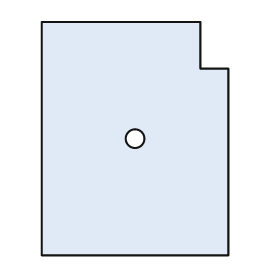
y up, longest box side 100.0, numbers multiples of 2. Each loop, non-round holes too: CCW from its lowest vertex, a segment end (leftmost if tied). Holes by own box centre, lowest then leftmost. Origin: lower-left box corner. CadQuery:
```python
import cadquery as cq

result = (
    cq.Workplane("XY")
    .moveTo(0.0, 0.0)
    .lineTo(80.0, 0.0)
    .lineTo(80.0, 80.0)
    .lineTo(68.0, 80.0)
    .lineTo(68.0, 100.0)
    .lineTo(0.0, 100.0)
    .close()
    .moveTo(40.0, 50.0)
    .circle(4.0)
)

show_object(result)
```